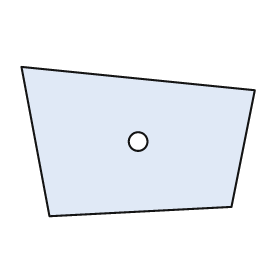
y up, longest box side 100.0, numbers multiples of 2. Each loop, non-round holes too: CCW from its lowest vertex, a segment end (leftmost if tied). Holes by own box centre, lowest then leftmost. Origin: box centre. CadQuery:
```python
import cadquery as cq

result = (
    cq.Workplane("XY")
    .moveTo(-38.0, -32.0)
    .lineTo(40.0, -28.0)
    .lineTo(50.0, 22.0)
    .lineTo(-50.0, 32.0)
    .close()
    .moveTo(0.0, 0.0)
    .circle(4.0)
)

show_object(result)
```